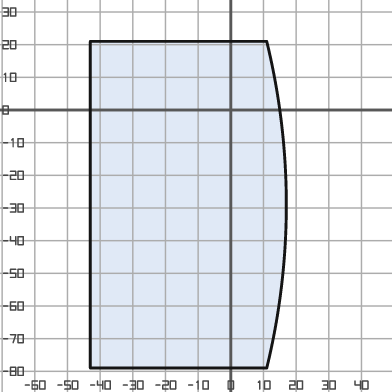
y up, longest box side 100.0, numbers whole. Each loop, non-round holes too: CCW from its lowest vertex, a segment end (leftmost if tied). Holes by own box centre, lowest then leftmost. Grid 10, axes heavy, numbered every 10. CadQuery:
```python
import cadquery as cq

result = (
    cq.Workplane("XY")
    .moveTo(-43.0, -79.0)
    .lineTo(11.0, -79.0)
    .threePointArc((17.0, -29.0), (11.0, 21.0))
    .lineTo(-43.0, 21.0)
    .close()
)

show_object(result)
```